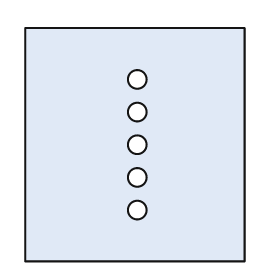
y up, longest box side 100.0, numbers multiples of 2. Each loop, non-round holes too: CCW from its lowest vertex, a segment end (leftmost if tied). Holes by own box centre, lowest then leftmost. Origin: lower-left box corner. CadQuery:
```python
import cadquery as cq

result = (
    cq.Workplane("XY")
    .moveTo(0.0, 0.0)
    .lineTo(94.0, 0.0)
    .lineTo(94.0, 100.0)
    .lineTo(0.0, 100.0)
    .close()
    .moveTo(48.0, 22.0)
    .circle(4.0)
    .moveTo(48.0, 36.0)
    .circle(4.0)
    .moveTo(48.0, 50.0)
    .circle(4.0)
    .moveTo(48.0, 64.0)
    .circle(4.0)
    .moveTo(48.0, 78.0)
    .circle(4.0)
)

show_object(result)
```